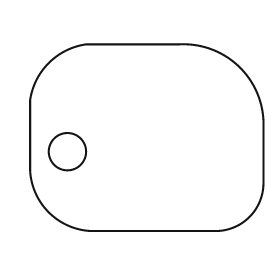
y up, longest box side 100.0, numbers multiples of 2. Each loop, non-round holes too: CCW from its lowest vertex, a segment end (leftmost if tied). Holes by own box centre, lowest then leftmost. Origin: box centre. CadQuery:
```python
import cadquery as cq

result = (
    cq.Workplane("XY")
    .moveTo(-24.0, -40.0)
    .lineTo(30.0, -40.0)
    .threePointArc((44.0, -34.0), (50.0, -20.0))
    .lineTo(50.0, 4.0)
    .threePointArc((40.0, 30.0), (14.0, 40.0))
    .lineTo(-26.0, 40.0)
    .threePointArc((-42.0, 32.0), (-50.0, 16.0))
    .lineTo(-50.0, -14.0)
    .threePointArc((-42.0, -32.0), (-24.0, -40.0))
    .close()
    .moveTo(-34.0, -6.0)
    .circle(8.0)
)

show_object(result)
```